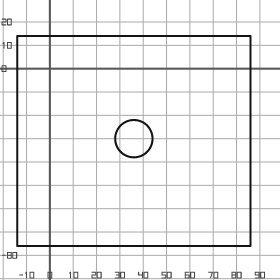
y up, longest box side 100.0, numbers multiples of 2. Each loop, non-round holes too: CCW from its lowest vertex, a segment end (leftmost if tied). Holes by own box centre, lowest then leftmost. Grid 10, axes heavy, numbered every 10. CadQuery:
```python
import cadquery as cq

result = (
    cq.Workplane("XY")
    .moveTo(-14.0, -76.0)
    .lineTo(86.0, -76.0)
    .lineTo(86.0, 14.0)
    .lineTo(-14.0, 14.0)
    .close()
    .moveTo(36.0, -30.0)
    .circle(8.0)
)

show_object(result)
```